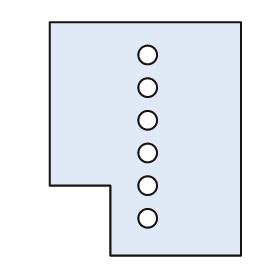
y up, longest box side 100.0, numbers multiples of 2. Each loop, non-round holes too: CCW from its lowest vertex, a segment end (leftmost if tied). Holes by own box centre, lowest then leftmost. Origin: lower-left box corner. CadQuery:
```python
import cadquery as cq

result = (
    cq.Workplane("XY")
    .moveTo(26.0, 0.0)
    .lineTo(82.0, 0.0)
    .lineTo(82.0, 100.0)
    .lineTo(0.0, 100.0)
    .lineTo(0.0, 30.0)
    .lineTo(26.0, 30.0)
    .close()
    .moveTo(42.0, 16.0)
    .circle(4.0)
    .moveTo(42.0, 30.0)
    .circle(4.0)
    .moveTo(42.0, 44.0)
    .circle(4.0)
    .moveTo(42.0, 58.0)
    .circle(4.0)
    .moveTo(42.0, 72.0)
    .circle(4.0)
    .moveTo(42.0, 86.0)
    .circle(4.0)
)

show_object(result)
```